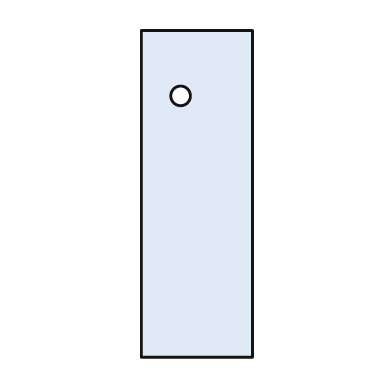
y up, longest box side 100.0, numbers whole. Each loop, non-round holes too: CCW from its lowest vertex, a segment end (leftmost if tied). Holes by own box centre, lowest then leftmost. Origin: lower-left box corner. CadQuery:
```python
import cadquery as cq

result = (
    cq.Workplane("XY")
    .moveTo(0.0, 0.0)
    .lineTo(34.0, 0.0)
    .lineTo(34.0, 100.0)
    .lineTo(0.0, 100.0)
    .close()
    .moveTo(12.0, 80.0)
    .circle(3.0)
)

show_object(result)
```